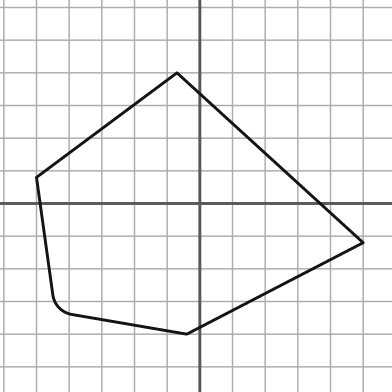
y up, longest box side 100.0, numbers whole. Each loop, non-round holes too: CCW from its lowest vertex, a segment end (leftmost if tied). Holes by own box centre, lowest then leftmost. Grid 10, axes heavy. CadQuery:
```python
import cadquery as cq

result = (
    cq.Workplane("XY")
    .moveTo(-4.0, -40.0)
    .lineTo(50.0, -12.0)
    .lineTo(-7.0, 40.0)
    .lineTo(-50.0, 8.0)
    .lineTo(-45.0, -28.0)
    .threePointArc((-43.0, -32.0), (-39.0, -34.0))
    .close()
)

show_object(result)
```